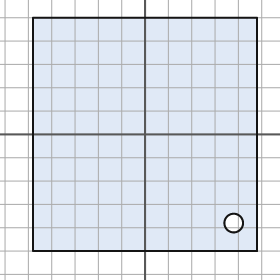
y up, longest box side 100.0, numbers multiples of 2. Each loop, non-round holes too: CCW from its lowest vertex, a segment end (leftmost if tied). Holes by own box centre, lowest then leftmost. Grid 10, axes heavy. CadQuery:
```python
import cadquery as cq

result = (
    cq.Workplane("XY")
    .moveTo(-48.0, -50.0)
    .lineTo(48.0, -50.0)
    .lineTo(48.0, 50.0)
    .lineTo(-48.0, 50.0)
    .close()
    .moveTo(38.0, -38.0)
    .circle(4.0)
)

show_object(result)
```